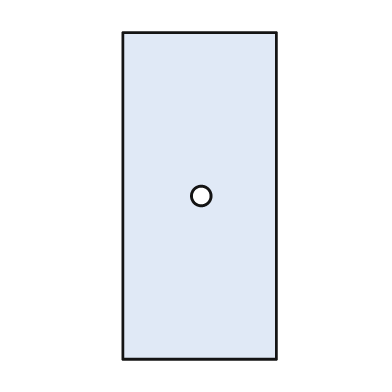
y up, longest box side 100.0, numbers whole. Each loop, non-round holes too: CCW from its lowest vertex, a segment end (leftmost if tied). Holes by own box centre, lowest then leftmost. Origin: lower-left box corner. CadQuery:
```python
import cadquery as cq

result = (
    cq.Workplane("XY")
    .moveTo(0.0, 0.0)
    .lineTo(47.0, 0.0)
    .lineTo(47.0, 100.0)
    .lineTo(0.0, 100.0)
    .close()
    .moveTo(24.0, 50.0)
    .circle(3.0)
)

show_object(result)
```